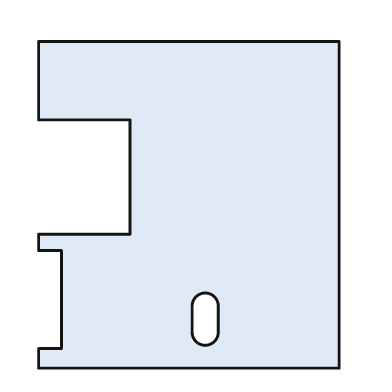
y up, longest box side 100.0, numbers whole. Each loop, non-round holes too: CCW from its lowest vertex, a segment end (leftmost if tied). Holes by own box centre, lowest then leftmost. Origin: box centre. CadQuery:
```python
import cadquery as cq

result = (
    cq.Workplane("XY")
    .moveTo(-46.0, -50.0)
    .lineTo(46.0, -50.0)
    .lineTo(46.0, 50.0)
    .lineTo(-46.0, 50.0)
    .lineTo(-46.0, 26.0)
    .lineTo(-18.0, 26.0)
    .lineTo(-18.0, -9.0)
    .lineTo(-46.0, -9.0)
    .lineTo(-46.0, -14.0)
    .lineTo(-39.0, -14.0)
    .lineTo(-39.0, -44.0)
    .lineTo(-46.0, -44.0)
    .close()
    .moveTo(1.0, -39.0)
    .threePointArc((5.0, -43.0), (9.0, -39.0))
    .lineTo(9.0, -31.0)
    .threePointArc((5.0, -27.0), (1.0, -31.0))
    .close()
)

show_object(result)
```